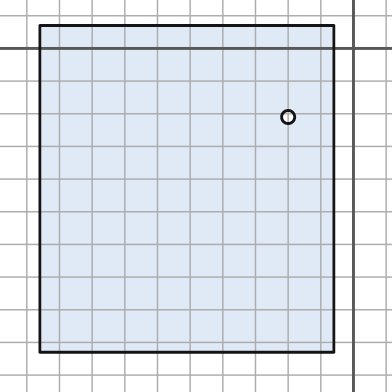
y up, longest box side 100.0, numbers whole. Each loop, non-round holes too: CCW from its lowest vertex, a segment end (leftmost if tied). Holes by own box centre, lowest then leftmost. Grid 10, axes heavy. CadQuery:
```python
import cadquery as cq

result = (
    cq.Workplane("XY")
    .moveTo(-96.0, -93.0)
    .lineTo(-6.0, -93.0)
    .lineTo(-6.0, 7.0)
    .lineTo(-96.0, 7.0)
    .close()
    .moveTo(-20.0, -21.0)
    .circle(2.0)
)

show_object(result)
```